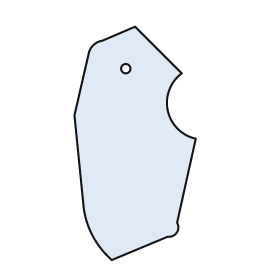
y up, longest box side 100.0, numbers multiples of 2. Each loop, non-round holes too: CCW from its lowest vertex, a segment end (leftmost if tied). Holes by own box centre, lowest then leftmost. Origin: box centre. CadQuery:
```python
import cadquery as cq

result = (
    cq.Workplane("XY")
    .moveTo(-10.0, -50.0)
    .lineTo(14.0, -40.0)
    .threePointArc((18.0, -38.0), (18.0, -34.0))
    .lineTo(26.0, 2.0)
    .threePointArc((14.0, 14.0), (20.0, 30.0))
    .lineTo(0.0, 50.0)
    .lineTo(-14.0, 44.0)
    .threePointArc((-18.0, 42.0), (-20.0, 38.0))
    .lineTo(-26.0, 12.0)
    .lineTo(-22.0, -28.0)
    .threePointArc((-18.0, -40.0), (-10.0, -50.0))
    .close()
    .moveTo(-4.0, 32.0)
    .circle(2.0)
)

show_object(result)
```